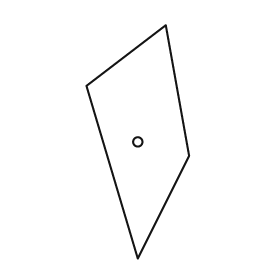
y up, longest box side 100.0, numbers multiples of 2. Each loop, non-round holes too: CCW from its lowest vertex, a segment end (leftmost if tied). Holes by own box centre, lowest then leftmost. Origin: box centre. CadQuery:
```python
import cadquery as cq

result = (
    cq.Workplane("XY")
    .moveTo(0.0, -50.0)
    .lineTo(22.0, -6.0)
    .lineTo(12.0, 50.0)
    .lineTo(-22.0, 24.0)
    .close()
    .moveTo(0.0, 0.0)
    .circle(2.0)
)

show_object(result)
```